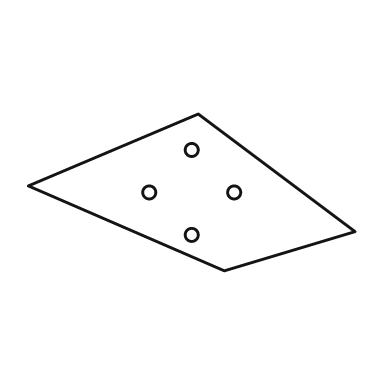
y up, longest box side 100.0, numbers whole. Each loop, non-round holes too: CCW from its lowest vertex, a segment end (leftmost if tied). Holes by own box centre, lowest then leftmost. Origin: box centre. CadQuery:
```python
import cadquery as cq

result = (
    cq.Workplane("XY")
    .moveTo(10.0, -24.0)
    .lineTo(50.0, -12.0)
    .lineTo(2.0, 24.0)
    .lineTo(-50.0, 2.0)
    .close()
    .moveTo(0.0, -13.0)
    .circle(2.0)
    .moveTo(-13.0, 0.0)
    .circle(2.0)
    .moveTo(13.0, 0.0)
    .circle(2.0)
    .moveTo(0.0, 13.0)
    .circle(2.0)
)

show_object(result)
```